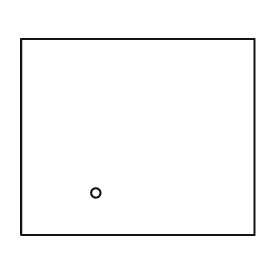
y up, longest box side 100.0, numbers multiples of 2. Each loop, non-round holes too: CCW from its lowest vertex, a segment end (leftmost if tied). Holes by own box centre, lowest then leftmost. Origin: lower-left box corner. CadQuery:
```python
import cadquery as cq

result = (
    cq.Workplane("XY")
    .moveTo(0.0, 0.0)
    .lineTo(100.0, 0.0)
    .lineTo(100.0, 84.0)
    .lineTo(0.0, 84.0)
    .close()
    .moveTo(32.0, 18.0)
    .circle(2.0)
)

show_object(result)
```